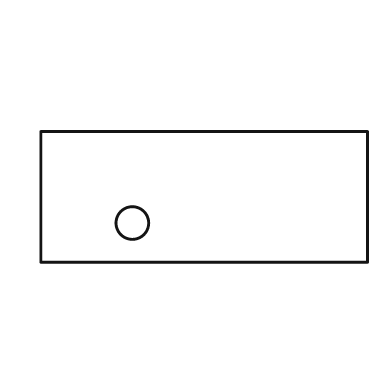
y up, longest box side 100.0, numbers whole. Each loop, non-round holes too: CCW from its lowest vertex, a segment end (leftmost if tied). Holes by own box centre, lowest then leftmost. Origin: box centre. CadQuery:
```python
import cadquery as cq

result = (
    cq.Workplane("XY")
    .moveTo(-50.0, -20.0)
    .lineTo(50.0, -20.0)
    .lineTo(50.0, 20.0)
    .lineTo(-50.0, 20.0)
    .close()
    .moveTo(-22.0, -8.0)
    .circle(5.0)
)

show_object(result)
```